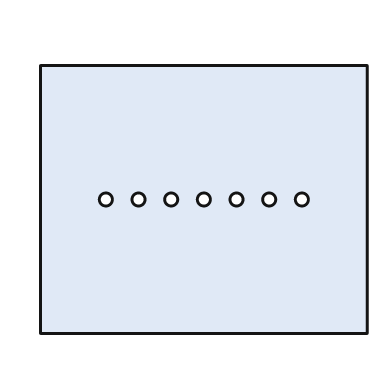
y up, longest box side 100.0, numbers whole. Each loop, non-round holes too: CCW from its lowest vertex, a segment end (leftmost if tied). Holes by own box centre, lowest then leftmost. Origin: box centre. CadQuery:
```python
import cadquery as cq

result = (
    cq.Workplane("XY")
    .moveTo(-50.0, -41.0)
    .lineTo(50.0, -41.0)
    .lineTo(50.0, 41.0)
    .lineTo(-50.0, 41.0)
    .close()
    .moveTo(-30.0, 0.0)
    .circle(2.0)
    .moveTo(-20.0, 0.0)
    .circle(2.0)
    .moveTo(-10.0, 0.0)
    .circle(2.0)
    .moveTo(0.0, 0.0)
    .circle(2.0)
    .moveTo(10.0, 0.0)
    .circle(2.0)
    .moveTo(20.0, 0.0)
    .circle(2.0)
    .moveTo(30.0, 0.0)
    .circle(2.0)
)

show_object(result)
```